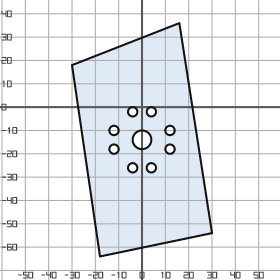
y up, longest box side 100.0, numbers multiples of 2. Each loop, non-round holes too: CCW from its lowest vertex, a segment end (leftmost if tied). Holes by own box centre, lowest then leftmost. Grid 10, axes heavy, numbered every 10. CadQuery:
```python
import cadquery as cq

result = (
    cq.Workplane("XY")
    .moveTo(-18.0, -64.0)
    .lineTo(30.0, -54.0)
    .lineTo(16.0, 36.0)
    .lineTo(-30.0, 18.0)
    .close()
    .moveTo(-4.0, -26.0)
    .circle(2.0)
    .moveTo(4.0, -26.0)
    .circle(2.0)
    .moveTo(-12.0, -18.0)
    .circle(2.0)
    .moveTo(12.0, -18.0)
    .circle(2.0)
    .moveTo(0.0, -14.0)
    .circle(4.0)
    .moveTo(-12.0, -10.0)
    .circle(2.0)
    .moveTo(12.0, -10.0)
    .circle(2.0)
    .moveTo(-4.0, -2.0)
    .circle(2.0)
    .moveTo(4.0, -2.0)
    .circle(2.0)
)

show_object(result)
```